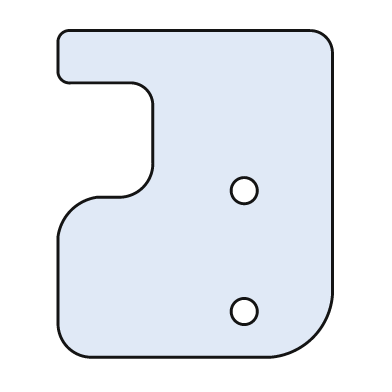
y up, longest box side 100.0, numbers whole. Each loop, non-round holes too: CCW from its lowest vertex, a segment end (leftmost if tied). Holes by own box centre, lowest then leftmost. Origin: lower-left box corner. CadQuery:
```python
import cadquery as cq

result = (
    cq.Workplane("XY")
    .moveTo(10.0, 0.0)
    .lineTo(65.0, 0.0)
    .threePointArc((78.0, 6.0), (84.0, 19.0))
    .lineTo(84.0, 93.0)
    .threePointArc((82.0, 98.0), (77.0, 100.0))
    .lineTo(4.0, 100.0)
    .threePointArc((1.0, 99.0), (0.0, 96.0))
    .lineTo(0.0, 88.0)
    .threePointArc((1.0, 85.0), (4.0, 84.0))
    .lineTo(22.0, 84.0)
    .threePointArc((27.0, 82.0), (29.0, 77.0))
    .lineTo(29.0, 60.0)
    .threePointArc((26.0, 52.0), (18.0, 49.0))
    .lineTo(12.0, 49.0)
    .threePointArc((4.0, 45.0), (0.0, 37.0))
    .lineTo(0.0, 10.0)
    .threePointArc((3.0, 3.0), (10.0, 0.0))
    .close()
    .moveTo(57.0, 14.0)
    .circle(4.0)
    .moveTo(57.0, 51.0)
    .circle(4.0)
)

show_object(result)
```